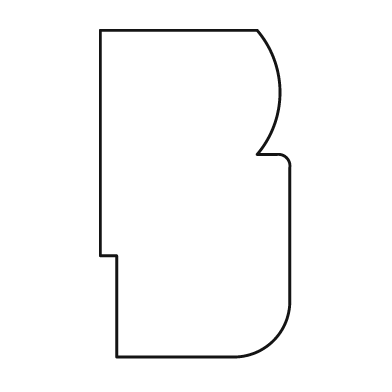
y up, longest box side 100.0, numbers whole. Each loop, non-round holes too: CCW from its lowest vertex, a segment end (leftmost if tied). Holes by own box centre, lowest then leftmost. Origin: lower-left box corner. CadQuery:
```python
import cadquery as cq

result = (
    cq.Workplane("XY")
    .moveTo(5.0, 0.0)
    .lineTo(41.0, 0.0)
    .threePointArc((53.0, 5.0), (58.0, 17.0))
    .lineTo(58.0, 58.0)
    .threePointArc((57.0, 61.0), (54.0, 62.0))
    .lineTo(48.0, 62.0)
    .threePointArc((55.0, 81.0), (48.0, 100.0))
    .lineTo(0.0, 100.0)
    .lineTo(0.0, 31.0)
    .lineTo(5.0, 31.0)
    .close()
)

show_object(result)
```